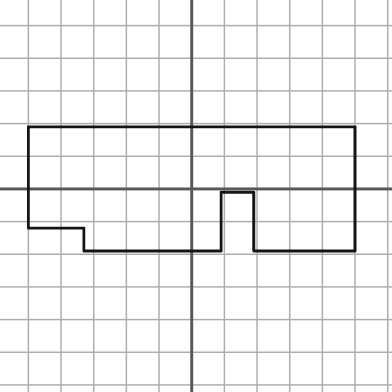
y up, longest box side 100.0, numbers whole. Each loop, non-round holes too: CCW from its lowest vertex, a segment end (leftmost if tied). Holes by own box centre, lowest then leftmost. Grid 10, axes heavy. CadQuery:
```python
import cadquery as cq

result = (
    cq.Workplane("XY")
    .moveTo(-33.0, -19.0)
    .lineTo(9.0, -19.0)
    .lineTo(9.0, -1.0)
    .lineTo(19.0, -1.0)
    .lineTo(19.0, -19.0)
    .lineTo(50.0, -19.0)
    .lineTo(50.0, 19.0)
    .lineTo(-50.0, 19.0)
    .lineTo(-50.0, -12.0)
    .lineTo(-33.0, -12.0)
    .close()
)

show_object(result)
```